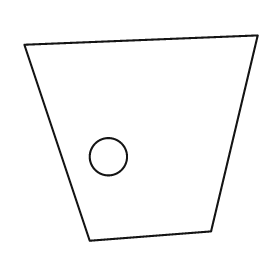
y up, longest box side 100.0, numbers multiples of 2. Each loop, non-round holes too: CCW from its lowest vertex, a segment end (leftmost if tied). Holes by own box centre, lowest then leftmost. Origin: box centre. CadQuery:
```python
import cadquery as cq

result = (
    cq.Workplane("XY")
    .moveTo(-22.0, -44.0)
    .lineTo(30.0, -40.0)
    .lineTo(50.0, 44.0)
    .lineTo(-50.0, 40.0)
    .close()
    .moveTo(-14.0, -8.0)
    .circle(8.0)
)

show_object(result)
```